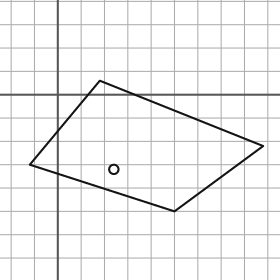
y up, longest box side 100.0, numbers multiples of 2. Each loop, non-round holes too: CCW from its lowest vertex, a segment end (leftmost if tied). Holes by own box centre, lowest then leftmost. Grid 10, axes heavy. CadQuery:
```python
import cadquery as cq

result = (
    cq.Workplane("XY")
    .moveTo(50.0, -50.0)
    .lineTo(88.0, -22.0)
    .lineTo(18.0, 6.0)
    .lineTo(-12.0, -30.0)
    .close()
    .moveTo(24.0, -32.0)
    .circle(2.0)
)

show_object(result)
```